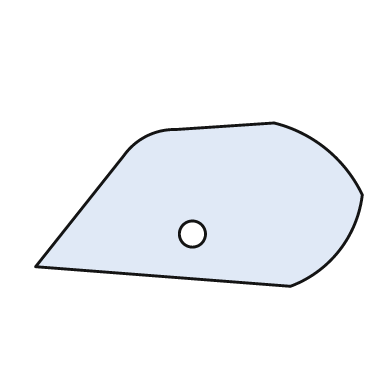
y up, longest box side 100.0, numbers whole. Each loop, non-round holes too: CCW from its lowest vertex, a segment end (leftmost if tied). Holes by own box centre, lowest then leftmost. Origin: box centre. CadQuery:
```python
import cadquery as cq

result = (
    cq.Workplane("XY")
    .moveTo(28.0, -25.0)
    .threePointArc((43.0, -14.0), (50.0, 3.0))
    .threePointArc((39.0, 17.0), (23.0, 25.0))
    .lineTo(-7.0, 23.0)
    .threePointArc((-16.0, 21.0), (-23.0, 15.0))
    .lineTo(-50.0, -19.0)
    .close()
    .moveTo(-2.0, -9.0)
    .circle(4.0)
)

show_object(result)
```